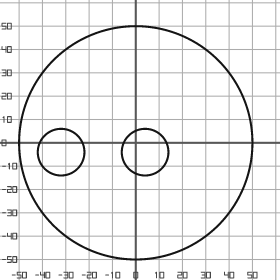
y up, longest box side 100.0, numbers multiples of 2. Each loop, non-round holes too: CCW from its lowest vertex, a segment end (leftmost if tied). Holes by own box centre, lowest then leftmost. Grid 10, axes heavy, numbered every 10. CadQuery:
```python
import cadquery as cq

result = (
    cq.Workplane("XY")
    .moveTo(0.0, 0.0)
    .circle(50.0)
    .moveTo(-32.0, -4.0)
    .circle(10.0)
    .moveTo(4.0, -4.0)
    .circle(10.0)
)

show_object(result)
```